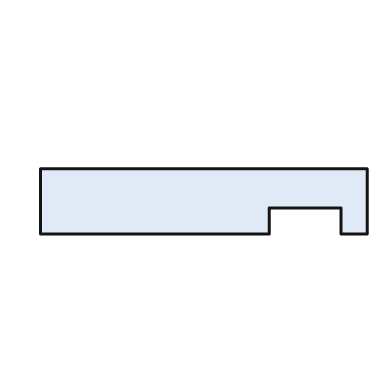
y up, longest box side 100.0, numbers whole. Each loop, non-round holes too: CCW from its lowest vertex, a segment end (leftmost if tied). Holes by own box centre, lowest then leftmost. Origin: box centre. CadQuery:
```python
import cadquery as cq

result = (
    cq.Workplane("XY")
    .moveTo(-50.0, -10.0)
    .lineTo(20.0, -10.0)
    .lineTo(20.0, -2.0)
    .lineTo(42.0, -2.0)
    .lineTo(42.0, -10.0)
    .lineTo(50.0, -10.0)
    .lineTo(50.0, 10.0)
    .lineTo(-50.0, 10.0)
    .close()
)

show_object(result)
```